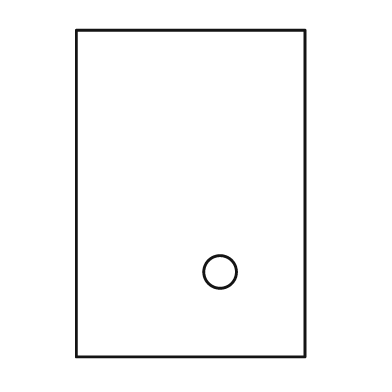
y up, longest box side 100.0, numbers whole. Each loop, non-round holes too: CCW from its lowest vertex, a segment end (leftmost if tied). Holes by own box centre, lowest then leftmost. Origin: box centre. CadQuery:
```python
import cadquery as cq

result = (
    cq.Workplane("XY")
    .moveTo(-35.0, -50.0)
    .lineTo(35.0, -50.0)
    .lineTo(35.0, 50.0)
    .lineTo(-35.0, 50.0)
    .close()
    .moveTo(9.0, -24.0)
    .circle(5.0)
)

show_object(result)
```